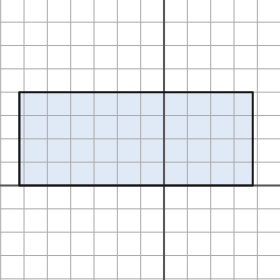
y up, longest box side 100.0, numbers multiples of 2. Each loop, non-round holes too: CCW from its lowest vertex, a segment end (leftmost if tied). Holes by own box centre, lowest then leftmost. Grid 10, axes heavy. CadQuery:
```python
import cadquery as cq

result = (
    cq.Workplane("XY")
    .moveTo(-62.0, 0.0)
    .lineTo(38.0, 0.0)
    .lineTo(38.0, 40.0)
    .lineTo(-62.0, 40.0)
    .close()
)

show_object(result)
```